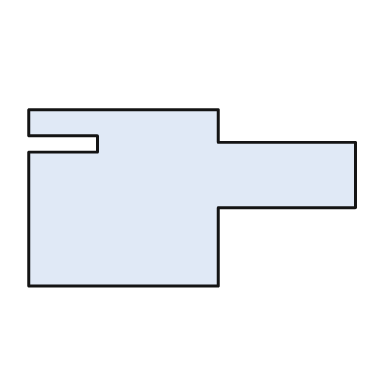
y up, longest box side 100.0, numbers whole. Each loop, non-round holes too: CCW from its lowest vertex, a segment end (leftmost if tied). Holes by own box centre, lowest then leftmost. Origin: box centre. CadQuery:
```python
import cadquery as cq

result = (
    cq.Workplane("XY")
    .moveTo(-50.0, -27.0)
    .lineTo(8.0, -27.0)
    .lineTo(8.0, -3.0)
    .lineTo(50.0, -3.0)
    .lineTo(50.0, 17.0)
    .lineTo(8.0, 17.0)
    .lineTo(8.0, 27.0)
    .lineTo(-50.0, 27.0)
    .lineTo(-50.0, 19.0)
    .lineTo(-29.0, 19.0)
    .lineTo(-29.0, 14.0)
    .lineTo(-50.0, 14.0)
    .close()
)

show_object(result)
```